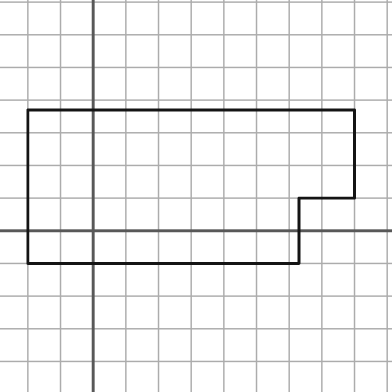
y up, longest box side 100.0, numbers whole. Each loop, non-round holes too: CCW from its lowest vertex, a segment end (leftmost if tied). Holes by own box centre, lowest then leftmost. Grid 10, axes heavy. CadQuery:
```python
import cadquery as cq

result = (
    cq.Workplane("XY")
    .moveTo(-20.0, -10.0)
    .lineTo(63.0, -10.0)
    .lineTo(63.0, 10.0)
    .lineTo(80.0, 10.0)
    .lineTo(80.0, 37.0)
    .lineTo(-20.0, 37.0)
    .close()
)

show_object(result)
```